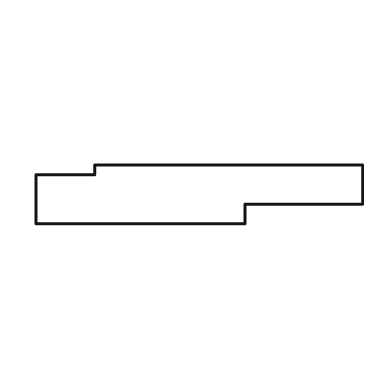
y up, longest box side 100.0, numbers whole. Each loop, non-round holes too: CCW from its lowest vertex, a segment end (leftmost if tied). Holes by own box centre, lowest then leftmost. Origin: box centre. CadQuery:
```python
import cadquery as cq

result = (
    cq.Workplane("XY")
    .moveTo(-50.0, -9.0)
    .lineTo(14.0, -9.0)
    .lineTo(14.0, -3.0)
    .lineTo(50.0, -3.0)
    .lineTo(50.0, 9.0)
    .lineTo(-32.0, 9.0)
    .lineTo(-32.0, 6.0)
    .lineTo(-50.0, 6.0)
    .close()
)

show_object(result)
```